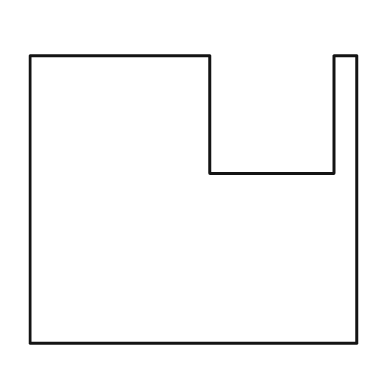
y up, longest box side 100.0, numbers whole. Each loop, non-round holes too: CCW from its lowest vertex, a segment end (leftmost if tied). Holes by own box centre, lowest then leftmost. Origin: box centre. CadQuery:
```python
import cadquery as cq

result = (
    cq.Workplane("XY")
    .moveTo(-50.0, -44.0)
    .lineTo(50.0, -44.0)
    .lineTo(50.0, 44.0)
    .lineTo(43.0, 44.0)
    .lineTo(43.0, 8.0)
    .lineTo(5.0, 8.0)
    .lineTo(5.0, 44.0)
    .lineTo(-50.0, 44.0)
    .close()
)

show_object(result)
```